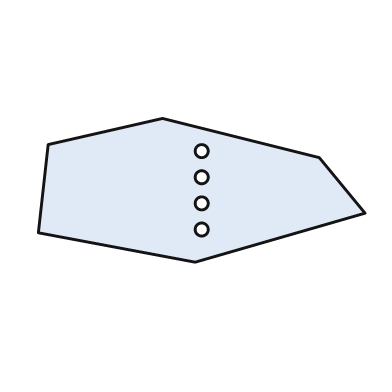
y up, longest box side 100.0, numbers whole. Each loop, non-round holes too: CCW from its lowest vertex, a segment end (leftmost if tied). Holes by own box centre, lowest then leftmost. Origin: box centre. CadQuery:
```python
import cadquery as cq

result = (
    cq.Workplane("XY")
    .moveTo(-2.0, -22.0)
    .lineTo(50.0, -7.0)
    .lineTo(36.0, 10.0)
    .lineTo(-12.0, 22.0)
    .lineTo(-47.0, 14.0)
    .lineTo(-50.0, -13.0)
    .close()
    .moveTo(0.0, -12.0)
    .circle(2.0)
    .moveTo(0.0, -4.0)
    .circle(2.0)
    .moveTo(0.0, 4.0)
    .circle(2.0)
    .moveTo(0.0, 12.0)
    .circle(2.0)
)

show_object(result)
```